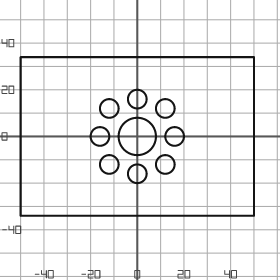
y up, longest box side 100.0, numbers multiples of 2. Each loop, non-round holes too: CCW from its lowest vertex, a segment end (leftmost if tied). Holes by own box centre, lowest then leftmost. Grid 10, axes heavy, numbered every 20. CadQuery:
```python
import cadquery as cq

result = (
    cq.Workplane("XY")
    .moveTo(-50.0, -34.0)
    .lineTo(50.0, -34.0)
    .lineTo(50.0, 34.0)
    .lineTo(-50.0, 34.0)
    .close()
    .moveTo(0.0, -16.0)
    .circle(4.0)
    .moveTo(-12.0, -12.0)
    .circle(4.0)
    .moveTo(12.0, -12.0)
    .circle(4.0)
    .moveTo(-16.0, 0.0)
    .circle(4.0)
    .moveTo(0.0, 0.0)
    .circle(8.0)
    .moveTo(16.0, 0.0)
    .circle(4.0)
    .moveTo(-12.0, 12.0)
    .circle(4.0)
    .moveTo(12.0, 12.0)
    .circle(4.0)
    .moveTo(0.0, 16.0)
    .circle(4.0)
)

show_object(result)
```